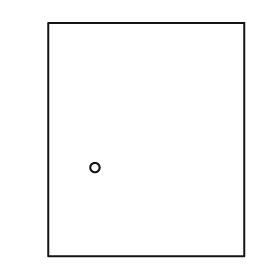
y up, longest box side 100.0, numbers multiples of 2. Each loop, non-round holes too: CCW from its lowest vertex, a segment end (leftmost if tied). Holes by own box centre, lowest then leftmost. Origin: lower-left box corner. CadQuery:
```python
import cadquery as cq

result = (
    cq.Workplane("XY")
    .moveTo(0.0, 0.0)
    .lineTo(84.0, 0.0)
    .lineTo(84.0, 100.0)
    .lineTo(0.0, 100.0)
    .close()
    .moveTo(20.0, 38.0)
    .circle(2.0)
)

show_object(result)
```